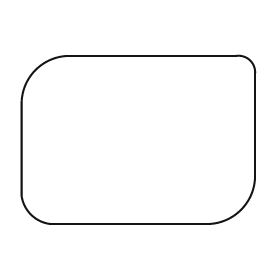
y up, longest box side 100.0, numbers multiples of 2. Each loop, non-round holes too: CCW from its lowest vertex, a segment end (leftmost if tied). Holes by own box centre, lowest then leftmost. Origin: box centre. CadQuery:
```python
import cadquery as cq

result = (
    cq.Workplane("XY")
    .moveTo(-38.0, -36.0)
    .lineTo(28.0, -36.0)
    .threePointArc((44.0, -30.0), (50.0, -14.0))
    .lineTo(50.0, 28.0)
    .threePointArc((48.0, 34.0), (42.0, 36.0))
    .lineTo(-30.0, 36.0)
    .threePointArc((-44.0, 30.0), (-50.0, 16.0))
    .lineTo(-50.0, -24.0)
    .threePointArc((-46.0, -32.0), (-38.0, -36.0))
    .close()
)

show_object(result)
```